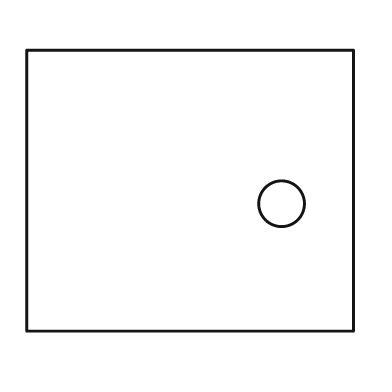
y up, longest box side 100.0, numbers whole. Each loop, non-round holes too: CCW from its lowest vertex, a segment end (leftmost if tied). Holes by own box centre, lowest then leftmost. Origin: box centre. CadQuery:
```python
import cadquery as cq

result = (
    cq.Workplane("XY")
    .moveTo(-50.0, -43.0)
    .lineTo(50.0, -43.0)
    .lineTo(50.0, 43.0)
    .lineTo(-50.0, 43.0)
    .close()
    .moveTo(28.0, -4.0)
    .circle(7.0)
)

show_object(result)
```